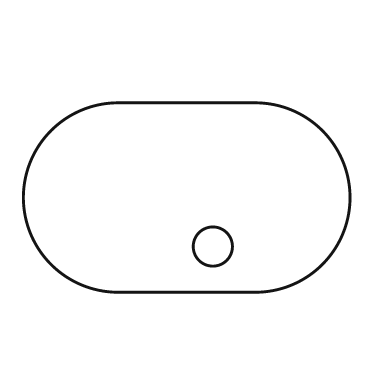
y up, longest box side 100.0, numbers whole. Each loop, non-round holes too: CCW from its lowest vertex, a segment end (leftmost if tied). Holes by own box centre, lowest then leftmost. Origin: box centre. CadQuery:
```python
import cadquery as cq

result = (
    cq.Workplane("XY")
    .moveTo(-21.0, -29.0)
    .lineTo(21.0, -29.0)
    .threePointArc((50.0, 0.0), (21.0, 29.0))
    .lineTo(-21.0, 29.0)
    .threePointArc((-50.0, 0.0), (-21.0, -29.0))
    .close()
    .moveTo(8.0, -15.0)
    .circle(6.0)
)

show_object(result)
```